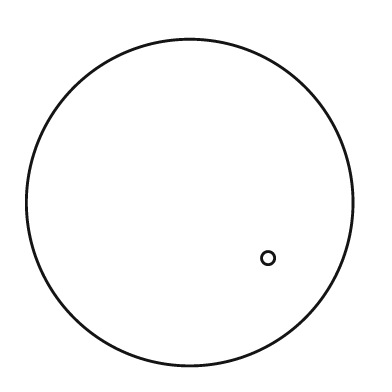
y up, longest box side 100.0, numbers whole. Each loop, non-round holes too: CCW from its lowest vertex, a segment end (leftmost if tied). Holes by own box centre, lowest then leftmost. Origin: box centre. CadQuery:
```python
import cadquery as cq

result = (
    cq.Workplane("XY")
    .moveTo(0.0, 0.0)
    .circle(50.0)
    .moveTo(24.0, -17.0)
    .circle(2.0)
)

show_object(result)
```